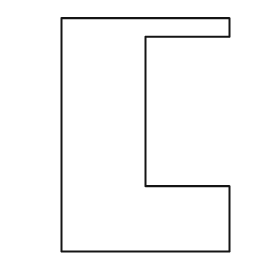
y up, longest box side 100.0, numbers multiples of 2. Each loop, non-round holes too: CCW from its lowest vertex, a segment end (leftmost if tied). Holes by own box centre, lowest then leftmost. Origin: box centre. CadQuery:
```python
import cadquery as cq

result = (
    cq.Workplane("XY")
    .moveTo(-36.0, -50.0)
    .lineTo(36.0, -50.0)
    .lineTo(36.0, -22.0)
    .lineTo(0.0, -22.0)
    .lineTo(0.0, 42.0)
    .lineTo(36.0, 42.0)
    .lineTo(36.0, 50.0)
    .lineTo(-36.0, 50.0)
    .close()
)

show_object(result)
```